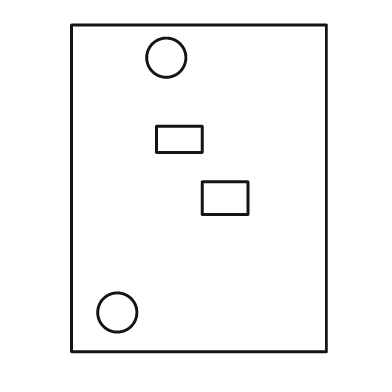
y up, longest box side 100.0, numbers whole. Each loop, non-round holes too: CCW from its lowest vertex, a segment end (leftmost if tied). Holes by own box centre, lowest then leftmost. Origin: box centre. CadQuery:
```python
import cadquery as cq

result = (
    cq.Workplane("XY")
    .moveTo(-39.0, -50.0)
    .lineTo(39.0, -50.0)
    .lineTo(39.0, 50.0)
    .lineTo(-39.0, 50.0)
    .close()
    .moveTo(-25.0, -38.0)
    .circle(6.0)
    .moveTo(1.0, -8.0)
    .lineTo(15.0, -8.0)
    .lineTo(15.0, 2.0)
    .lineTo(1.0, 2.0)
    .close()
    .moveTo(-13.0, 11.0)
    .lineTo(1.0, 11.0)
    .lineTo(1.0, 19.0)
    .lineTo(-13.0, 19.0)
    .close()
    .moveTo(-10.0, 40.0)
    .circle(6.0)
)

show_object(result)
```